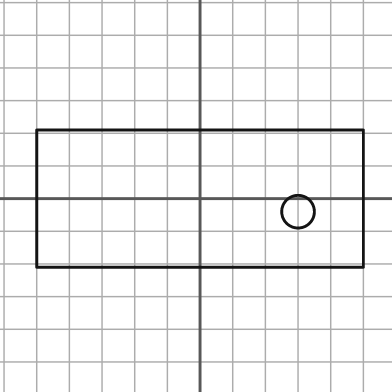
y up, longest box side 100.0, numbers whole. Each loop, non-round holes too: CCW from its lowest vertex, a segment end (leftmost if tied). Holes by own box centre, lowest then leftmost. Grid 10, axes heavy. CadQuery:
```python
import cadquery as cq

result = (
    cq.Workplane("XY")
    .moveTo(-50.0, -21.0)
    .lineTo(50.0, -21.0)
    .lineTo(50.0, 21.0)
    .lineTo(-50.0, 21.0)
    .close()
    .moveTo(30.0, -4.0)
    .circle(5.0)
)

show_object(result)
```